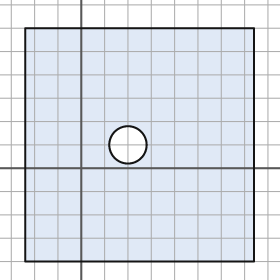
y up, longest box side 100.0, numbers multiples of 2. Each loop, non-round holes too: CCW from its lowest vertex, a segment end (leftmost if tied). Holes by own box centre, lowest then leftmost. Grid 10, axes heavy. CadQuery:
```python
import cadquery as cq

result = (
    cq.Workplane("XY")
    .moveTo(-24.0, -40.0)
    .lineTo(74.0, -40.0)
    .lineTo(74.0, 60.0)
    .lineTo(-24.0, 60.0)
    .close()
    .moveTo(20.0, 10.0)
    .circle(8.0)
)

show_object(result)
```